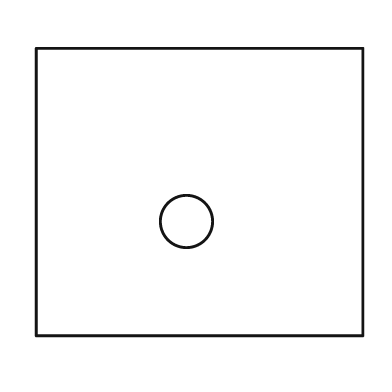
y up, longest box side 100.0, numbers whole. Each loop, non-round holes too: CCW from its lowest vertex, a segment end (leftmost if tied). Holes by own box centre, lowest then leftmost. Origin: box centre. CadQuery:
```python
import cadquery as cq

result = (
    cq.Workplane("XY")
    .moveTo(-50.0, -44.0)
    .lineTo(50.0, -44.0)
    .lineTo(50.0, 44.0)
    .lineTo(-50.0, 44.0)
    .close()
    .moveTo(-4.0, -9.0)
    .circle(8.0)
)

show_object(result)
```